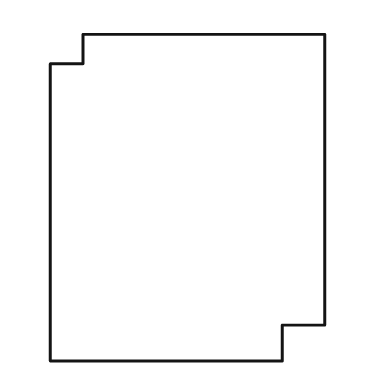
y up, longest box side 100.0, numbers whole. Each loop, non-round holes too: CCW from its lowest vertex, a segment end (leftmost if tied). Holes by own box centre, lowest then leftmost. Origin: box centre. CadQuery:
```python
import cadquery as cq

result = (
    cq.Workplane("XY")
    .moveTo(-42.0, -50.0)
    .lineTo(29.0, -50.0)
    .lineTo(29.0, -39.0)
    .lineTo(42.0, -39.0)
    .lineTo(42.0, 50.0)
    .lineTo(-32.0, 50.0)
    .lineTo(-32.0, 41.0)
    .lineTo(-42.0, 41.0)
    .close()
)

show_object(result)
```